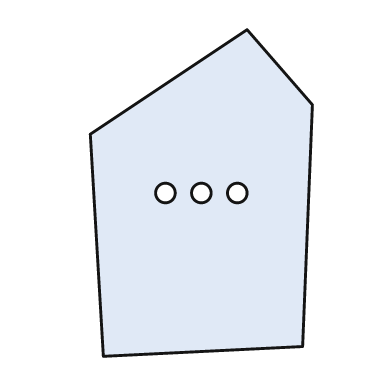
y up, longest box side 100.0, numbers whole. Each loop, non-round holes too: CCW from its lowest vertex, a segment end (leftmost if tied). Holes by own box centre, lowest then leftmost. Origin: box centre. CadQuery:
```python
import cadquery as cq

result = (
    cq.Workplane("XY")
    .moveTo(-30.0, -50.0)
    .lineTo(31.0, -47.0)
    .lineTo(34.0, 27.0)
    .lineTo(14.0, 50.0)
    .lineTo(-34.0, 18.0)
    .close()
    .moveTo(-11.0, 0.0)
    .circle(3.0)
    .moveTo(0.0, 0.0)
    .circle(3.0)
    .moveTo(11.0, 0.0)
    .circle(3.0)
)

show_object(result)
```